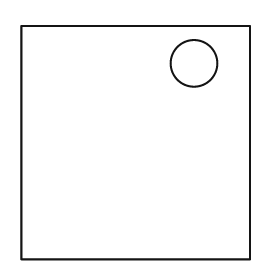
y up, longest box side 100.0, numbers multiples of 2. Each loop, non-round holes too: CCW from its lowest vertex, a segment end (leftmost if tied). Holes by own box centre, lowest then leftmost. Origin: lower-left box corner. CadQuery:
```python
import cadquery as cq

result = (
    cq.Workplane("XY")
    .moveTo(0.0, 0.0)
    .lineTo(98.0, 0.0)
    .lineTo(98.0, 100.0)
    .lineTo(0.0, 100.0)
    .close()
    .moveTo(74.0, 84.0)
    .circle(10.0)
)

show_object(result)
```